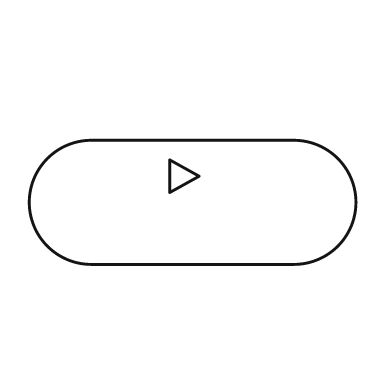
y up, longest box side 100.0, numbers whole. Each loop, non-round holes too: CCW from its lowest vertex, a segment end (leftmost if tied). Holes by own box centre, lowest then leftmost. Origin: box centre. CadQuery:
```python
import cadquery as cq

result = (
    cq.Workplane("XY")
    .moveTo(-31.0, -19.0)
    .lineTo(31.0, -19.0)
    .threePointArc((50.0, 0.0), (31.0, 19.0))
    .lineTo(-31.0, 19.0)
    .threePointArc((-50.0, 0.0), (-31.0, -19.0))
    .close()
    .moveTo(-7.0, 3.0)
    .lineTo(2.0, 8.0)
    .lineTo(-7.0, 13.0)
    .close()
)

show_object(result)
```